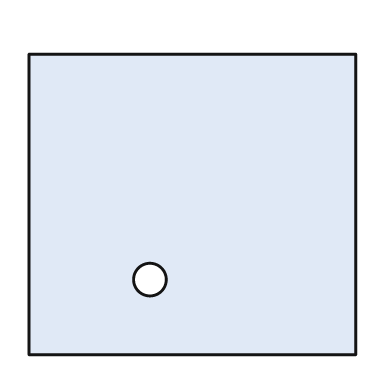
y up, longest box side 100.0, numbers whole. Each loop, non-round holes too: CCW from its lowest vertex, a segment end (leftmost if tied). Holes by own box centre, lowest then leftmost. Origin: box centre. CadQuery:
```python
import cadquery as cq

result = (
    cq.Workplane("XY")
    .moveTo(-50.0, -46.0)
    .lineTo(50.0, -46.0)
    .lineTo(50.0, 46.0)
    .lineTo(-50.0, 46.0)
    .close()
    .moveTo(-13.0, -23.0)
    .circle(5.0)
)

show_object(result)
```